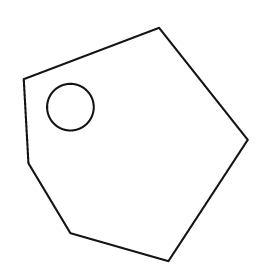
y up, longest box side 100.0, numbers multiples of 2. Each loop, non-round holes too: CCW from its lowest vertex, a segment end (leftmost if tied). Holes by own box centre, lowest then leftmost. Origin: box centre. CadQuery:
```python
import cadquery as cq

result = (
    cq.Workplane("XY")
    .moveTo(14.0, -50.0)
    .lineTo(48.0, 2.0)
    .lineTo(10.0, 50.0)
    .lineTo(-48.0, 28.0)
    .lineTo(-46.0, -8.0)
    .lineTo(-28.0, -38.0)
    .close()
    .moveTo(-28.0, 16.0)
    .circle(10.0)
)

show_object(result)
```